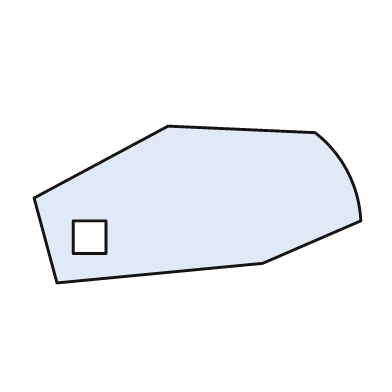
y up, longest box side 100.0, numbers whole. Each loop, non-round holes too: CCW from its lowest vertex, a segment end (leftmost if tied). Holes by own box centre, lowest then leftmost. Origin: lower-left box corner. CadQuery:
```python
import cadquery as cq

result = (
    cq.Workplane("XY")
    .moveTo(7.0, 0.0)
    .lineTo(70.0, 6.0)
    .lineTo(100.0, 19.0)
    .threePointArc((96.0, 34.0), (86.0, 46.0))
    .lineTo(41.0, 48.0)
    .lineTo(0.0, 26.0)
    .close()
    .moveTo(12.0, 9.0)
    .lineTo(22.0, 9.0)
    .lineTo(22.0, 19.0)
    .lineTo(12.0, 19.0)
    .close()
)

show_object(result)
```